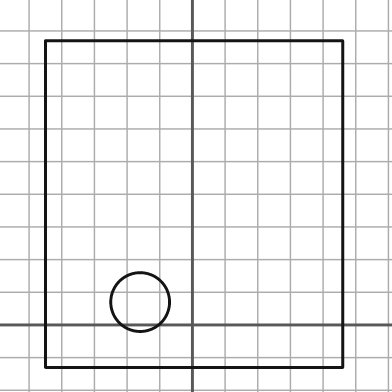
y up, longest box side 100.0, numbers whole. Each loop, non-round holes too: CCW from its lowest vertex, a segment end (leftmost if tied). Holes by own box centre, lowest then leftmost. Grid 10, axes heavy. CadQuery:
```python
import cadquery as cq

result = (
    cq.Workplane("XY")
    .moveTo(-45.0, -13.0)
    .lineTo(46.0, -13.0)
    .lineTo(46.0, 87.0)
    .lineTo(-45.0, 87.0)
    .close()
    .moveTo(-16.0, 7.0)
    .circle(9.0)
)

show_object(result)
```